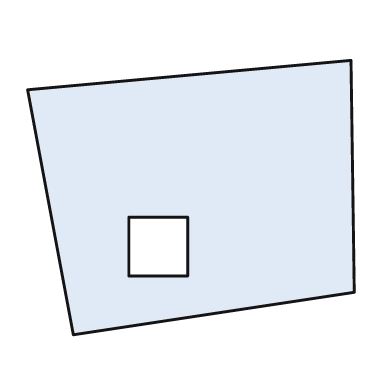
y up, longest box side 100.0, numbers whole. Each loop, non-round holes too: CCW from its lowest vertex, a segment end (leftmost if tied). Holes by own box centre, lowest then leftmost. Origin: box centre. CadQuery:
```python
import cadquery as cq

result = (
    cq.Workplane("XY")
    .moveTo(-36.0, -42.0)
    .lineTo(50.0, -29.0)
    .lineTo(49.0, 42.0)
    .lineTo(-50.0, 33.0)
    .close()
    .moveTo(-19.0, -24.0)
    .lineTo(-1.0, -24.0)
    .lineTo(-1.0, -6.0)
    .lineTo(-19.0, -6.0)
    .close()
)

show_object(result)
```